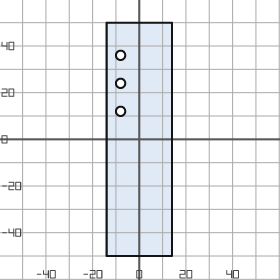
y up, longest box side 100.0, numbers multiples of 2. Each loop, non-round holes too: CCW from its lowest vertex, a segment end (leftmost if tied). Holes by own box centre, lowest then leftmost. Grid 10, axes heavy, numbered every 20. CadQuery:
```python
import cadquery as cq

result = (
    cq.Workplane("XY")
    .moveTo(-14.0, -50.0)
    .lineTo(14.0, -50.0)
    .lineTo(14.0, 50.0)
    .lineTo(-14.0, 50.0)
    .close()
    .moveTo(-8.0, 12.0)
    .circle(2.0)
    .moveTo(-8.0, 24.0)
    .circle(2.0)
    .moveTo(-8.0, 36.0)
    .circle(2.0)
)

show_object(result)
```